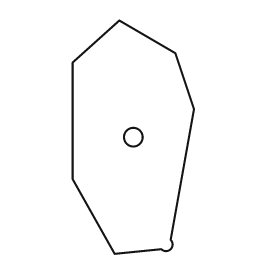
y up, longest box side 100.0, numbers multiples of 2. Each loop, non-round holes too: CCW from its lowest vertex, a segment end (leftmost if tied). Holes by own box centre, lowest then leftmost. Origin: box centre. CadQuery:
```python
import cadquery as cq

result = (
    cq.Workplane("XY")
    .moveTo(-8.0, -50.0)
    .lineTo(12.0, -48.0)
    .threePointArc((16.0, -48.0), (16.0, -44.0))
    .lineTo(26.0, 12.0)
    .lineTo(18.0, 36.0)
    .lineTo(-6.0, 50.0)
    .lineTo(-26.0, 32.0)
    .lineTo(-26.0, -18.0)
    .close()
    .moveTo(0.0, 0.0)
    .circle(4.0)
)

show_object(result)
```